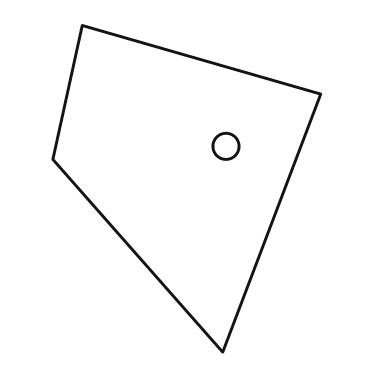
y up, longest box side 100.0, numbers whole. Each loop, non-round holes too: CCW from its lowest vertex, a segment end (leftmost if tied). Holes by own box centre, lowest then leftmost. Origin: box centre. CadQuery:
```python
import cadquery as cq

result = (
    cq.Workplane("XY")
    .moveTo(11.0, -50.0)
    .lineTo(41.0, 29.0)
    .lineTo(-32.0, 50.0)
    .lineTo(-41.0, 9.0)
    .close()
    .moveTo(12.0, 13.0)
    .circle(4.0)
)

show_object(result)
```